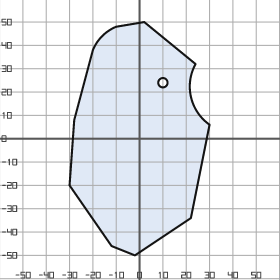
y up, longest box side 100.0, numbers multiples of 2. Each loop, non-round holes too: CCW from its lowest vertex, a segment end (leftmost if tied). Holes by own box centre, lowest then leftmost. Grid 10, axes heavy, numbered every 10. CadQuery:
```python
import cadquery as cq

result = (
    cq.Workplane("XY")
    .moveTo(-2.0, -50.0)
    .lineTo(22.0, -34.0)
    .lineTo(30.0, 6.0)
    .threePointArc((22.0, 18.0), (24.0, 32.0))
    .lineTo(2.0, 50.0)
    .lineTo(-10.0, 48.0)
    .threePointArc((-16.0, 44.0), (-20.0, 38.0))
    .lineTo(-28.0, 8.0)
    .lineTo(-30.0, -20.0)
    .lineTo(-12.0, -46.0)
    .close()
    .moveTo(10.0, 24.0)
    .circle(2.0)
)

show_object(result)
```